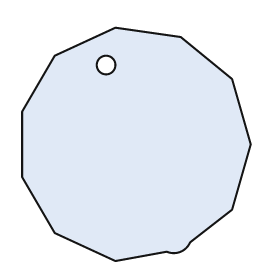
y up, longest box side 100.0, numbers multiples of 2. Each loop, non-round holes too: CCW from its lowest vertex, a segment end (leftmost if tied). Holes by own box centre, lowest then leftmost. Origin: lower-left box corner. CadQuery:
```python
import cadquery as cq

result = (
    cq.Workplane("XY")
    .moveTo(40.0, 0.0)
    .lineTo(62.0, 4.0)
    .threePointArc((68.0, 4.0), (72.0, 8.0))
    .lineTo(90.0, 22.0)
    .lineTo(98.0, 50.0)
    .lineTo(90.0, 78.0)
    .lineTo(68.0, 96.0)
    .lineTo(40.0, 100.0)
    .lineTo(14.0, 88.0)
    .lineTo(0.0, 64.0)
    .lineTo(0.0, 36.0)
    .lineTo(14.0, 12.0)
    .close()
    .moveTo(36.0, 84.0)
    .circle(4.0)
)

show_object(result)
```